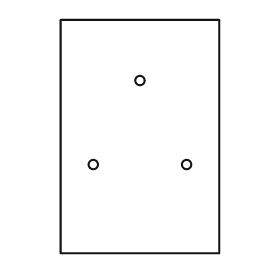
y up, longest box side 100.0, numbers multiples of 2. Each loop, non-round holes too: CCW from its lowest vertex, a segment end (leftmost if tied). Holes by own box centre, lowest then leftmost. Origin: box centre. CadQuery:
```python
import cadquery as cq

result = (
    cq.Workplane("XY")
    .moveTo(-34.0, -50.0)
    .lineTo(34.0, -50.0)
    .lineTo(34.0, 50.0)
    .lineTo(-34.0, 50.0)
    .close()
    .moveTo(-20.0, -12.0)
    .circle(2.0)
    .moveTo(20.0, -12.0)
    .circle(2.0)
    .moveTo(0.0, 24.0)
    .circle(2.0)
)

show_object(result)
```